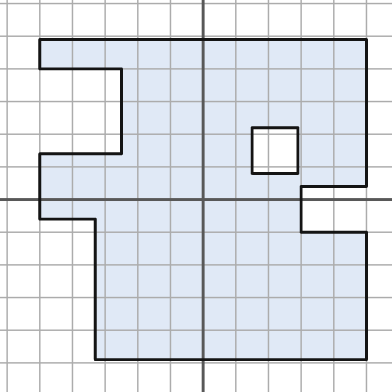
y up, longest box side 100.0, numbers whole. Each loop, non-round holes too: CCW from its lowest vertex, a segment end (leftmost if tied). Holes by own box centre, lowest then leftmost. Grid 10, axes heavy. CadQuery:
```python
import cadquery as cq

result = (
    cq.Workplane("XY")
    .moveTo(-33.0, -49.0)
    .lineTo(50.0, -49.0)
    .lineTo(50.0, -10.0)
    .lineTo(30.0, -10.0)
    .lineTo(30.0, 4.0)
    .lineTo(50.0, 4.0)
    .lineTo(50.0, 49.0)
    .lineTo(-50.0, 49.0)
    .lineTo(-50.0, 40.0)
    .lineTo(-25.0, 40.0)
    .lineTo(-25.0, 14.0)
    .lineTo(-50.0, 14.0)
    .lineTo(-50.0, -6.0)
    .lineTo(-33.0, -6.0)
    .close()
    .moveTo(15.0, 8.0)
    .lineTo(29.0, 8.0)
    .lineTo(29.0, 22.0)
    .lineTo(15.0, 22.0)
    .close()
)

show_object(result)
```